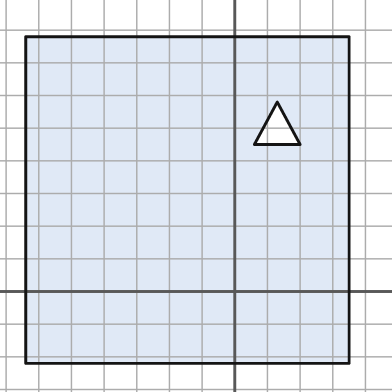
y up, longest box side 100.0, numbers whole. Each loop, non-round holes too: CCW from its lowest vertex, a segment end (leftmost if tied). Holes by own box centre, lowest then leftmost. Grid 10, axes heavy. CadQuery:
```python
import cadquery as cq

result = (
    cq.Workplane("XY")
    .moveTo(-64.0, -22.0)
    .lineTo(35.0, -22.0)
    .lineTo(35.0, 78.0)
    .lineTo(-64.0, 78.0)
    .close()
    .moveTo(6.0, 45.0)
    .lineTo(20.0, 45.0)
    .lineTo(13.0, 58.0)
    .close()
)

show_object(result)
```